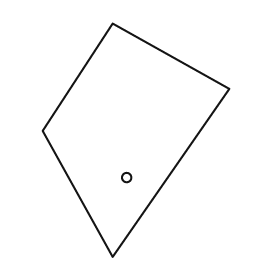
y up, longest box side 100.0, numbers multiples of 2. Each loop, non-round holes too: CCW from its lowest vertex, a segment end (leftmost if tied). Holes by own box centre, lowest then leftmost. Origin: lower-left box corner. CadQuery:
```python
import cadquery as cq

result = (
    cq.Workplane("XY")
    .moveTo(30.0, 0.0)
    .lineTo(80.0, 72.0)
    .lineTo(30.0, 100.0)
    .lineTo(0.0, 54.0)
    .close()
    .moveTo(36.0, 34.0)
    .circle(2.0)
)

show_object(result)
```